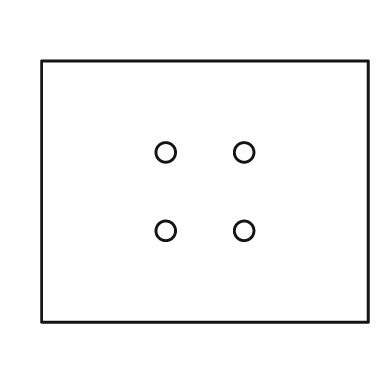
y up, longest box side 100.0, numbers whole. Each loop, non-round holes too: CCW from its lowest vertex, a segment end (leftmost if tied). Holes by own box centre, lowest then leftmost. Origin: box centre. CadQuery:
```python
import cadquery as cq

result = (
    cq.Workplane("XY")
    .moveTo(-50.0, -40.0)
    .lineTo(50.0, -40.0)
    .lineTo(50.0, 40.0)
    .lineTo(-50.0, 40.0)
    .close()
    .moveTo(-12.0, -12.0)
    .circle(3.0)
    .moveTo(12.0, -12.0)
    .circle(3.0)
    .moveTo(-12.0, 12.0)
    .circle(3.0)
    .moveTo(12.0, 12.0)
    .circle(3.0)
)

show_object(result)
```